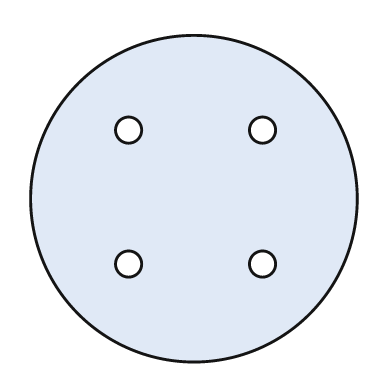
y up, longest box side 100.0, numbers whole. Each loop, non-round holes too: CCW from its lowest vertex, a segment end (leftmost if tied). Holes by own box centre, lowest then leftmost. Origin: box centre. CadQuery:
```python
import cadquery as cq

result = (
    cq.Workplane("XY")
    .moveTo(0.0, 0.0)
    .circle(50.0)
    .moveTo(-20.0, -20.0)
    .circle(4.0)
    .moveTo(21.0, -20.0)
    .circle(4.0)
    .moveTo(-20.0, 21.0)
    .circle(4.0)
    .moveTo(21.0, 21.0)
    .circle(4.0)
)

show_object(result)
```